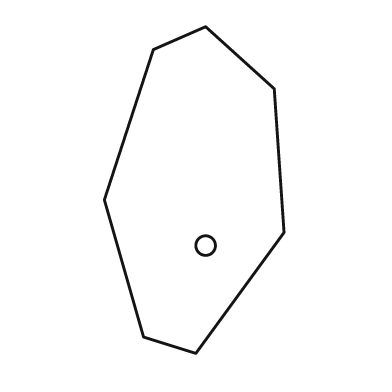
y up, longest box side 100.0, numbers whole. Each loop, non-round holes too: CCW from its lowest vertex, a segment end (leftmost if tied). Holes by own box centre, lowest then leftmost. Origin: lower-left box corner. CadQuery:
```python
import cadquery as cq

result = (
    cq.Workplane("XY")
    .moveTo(28.0, 0.0)
    .lineTo(55.0, 37.0)
    .lineTo(52.0, 81.0)
    .lineTo(31.0, 100.0)
    .lineTo(15.0, 93.0)
    .lineTo(0.0, 47.0)
    .lineTo(12.0, 5.0)
    .close()
    .moveTo(31.0, 33.0)
    .circle(3.0)
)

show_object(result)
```